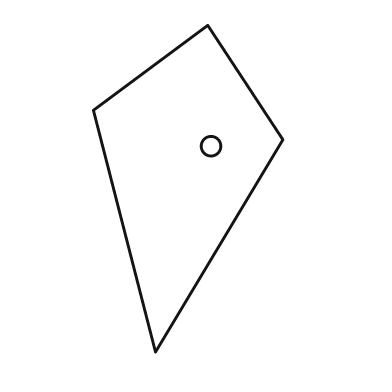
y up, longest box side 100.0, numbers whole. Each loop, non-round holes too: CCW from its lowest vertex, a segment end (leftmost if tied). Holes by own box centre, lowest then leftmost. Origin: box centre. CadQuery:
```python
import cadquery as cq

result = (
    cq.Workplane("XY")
    .moveTo(-10.0, -50.0)
    .lineTo(29.0, 15.0)
    .lineTo(6.0, 50.0)
    .lineTo(-29.0, 24.0)
    .close()
    .moveTo(7.0, 13.0)
    .circle(3.0)
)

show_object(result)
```